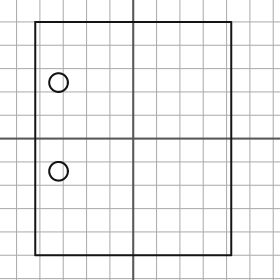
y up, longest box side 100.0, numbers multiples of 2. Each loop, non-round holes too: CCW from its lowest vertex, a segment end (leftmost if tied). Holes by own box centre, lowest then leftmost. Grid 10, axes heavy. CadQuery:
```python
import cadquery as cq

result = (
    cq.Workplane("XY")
    .moveTo(-42.0, -50.0)
    .lineTo(42.0, -50.0)
    .lineTo(42.0, 50.0)
    .lineTo(-42.0, 50.0)
    .close()
    .moveTo(-32.0, -14.0)
    .circle(4.0)
    .moveTo(-32.0, 24.0)
    .circle(4.0)
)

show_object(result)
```